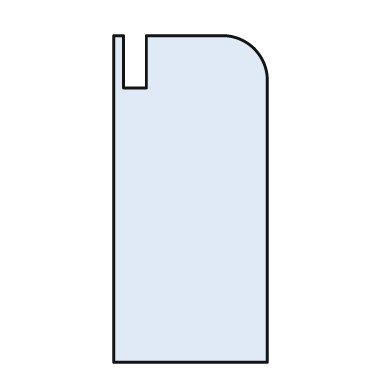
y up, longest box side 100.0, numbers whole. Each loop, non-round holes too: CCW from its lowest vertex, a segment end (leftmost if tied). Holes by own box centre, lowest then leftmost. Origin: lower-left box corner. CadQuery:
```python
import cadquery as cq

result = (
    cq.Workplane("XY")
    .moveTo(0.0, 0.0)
    .lineTo(47.0, 0.0)
    .lineTo(47.0, 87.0)
    .threePointArc((43.0, 96.0), (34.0, 100.0))
    .lineTo(10.0, 100.0)
    .lineTo(10.0, 84.0)
    .lineTo(3.0, 84.0)
    .lineTo(3.0, 100.0)
    .lineTo(0.0, 100.0)
    .close()
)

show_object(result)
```